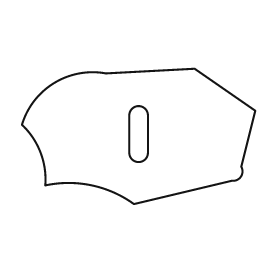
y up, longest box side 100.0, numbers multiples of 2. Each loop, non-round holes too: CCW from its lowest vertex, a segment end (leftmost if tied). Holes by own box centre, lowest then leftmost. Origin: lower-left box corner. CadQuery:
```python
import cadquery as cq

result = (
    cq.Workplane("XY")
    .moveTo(48.0, 0.0)
    .lineTo(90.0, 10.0)
    .threePointArc((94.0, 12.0), (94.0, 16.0))
    .lineTo(100.0, 40.0)
    .lineTo(74.0, 58.0)
    .lineTo(36.0, 56.0)
    .threePointArc((14.0, 52.0), (0.0, 34.0))
    .threePointArc((8.0, 22.0), (10.0, 8.0))
    .threePointArc((30.0, 8.0), (48.0, 0.0))
    .close()
    .moveTo(46.0, 22.0)
    .threePointArc((50.0, 18.0), (54.0, 22.0))
    .lineTo(54.0, 38.0)
    .threePointArc((50.0, 42.0), (46.0, 38.0))
    .close()
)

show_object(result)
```